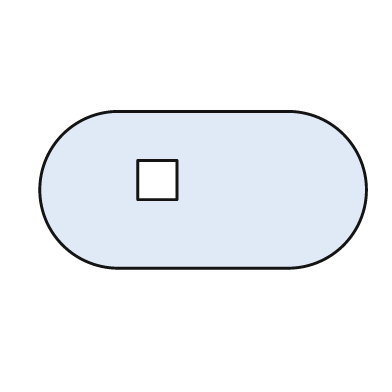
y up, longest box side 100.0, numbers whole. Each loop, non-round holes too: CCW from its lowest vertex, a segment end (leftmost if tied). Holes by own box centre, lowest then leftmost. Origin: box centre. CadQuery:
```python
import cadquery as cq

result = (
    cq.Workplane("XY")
    .moveTo(-26.0, -24.0)
    .lineTo(26.0, -24.0)
    .threePointArc((50.0, 0.0), (26.0, 24.0))
    .lineTo(-26.0, 24.0)
    .threePointArc((-50.0, 0.0), (-26.0, -24.0))
    .close()
    .moveTo(-20.0, -3.0)
    .lineTo(-8.0, -3.0)
    .lineTo(-8.0, 9.0)
    .lineTo(-20.0, 9.0)
    .close()
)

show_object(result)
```